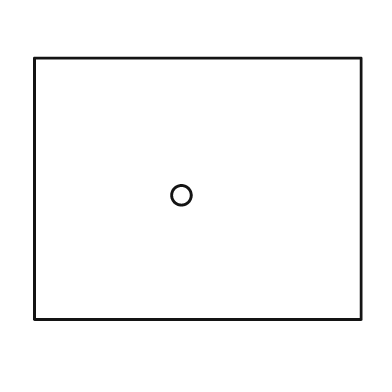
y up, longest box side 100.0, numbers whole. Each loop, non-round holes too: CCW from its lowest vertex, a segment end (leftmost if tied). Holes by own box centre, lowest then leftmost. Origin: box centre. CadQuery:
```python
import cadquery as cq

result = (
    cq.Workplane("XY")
    .moveTo(-50.0, -40.0)
    .lineTo(50.0, -40.0)
    .lineTo(50.0, 40.0)
    .lineTo(-50.0, 40.0)
    .close()
    .moveTo(-5.0, -2.0)
    .circle(3.0)
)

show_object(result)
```